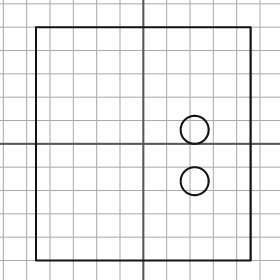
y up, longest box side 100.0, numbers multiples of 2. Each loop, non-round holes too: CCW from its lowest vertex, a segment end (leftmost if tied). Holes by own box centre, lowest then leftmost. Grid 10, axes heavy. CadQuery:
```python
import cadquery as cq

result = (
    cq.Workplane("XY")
    .moveTo(-46.0, -50.0)
    .lineTo(46.0, -50.0)
    .lineTo(46.0, 50.0)
    .lineTo(-46.0, 50.0)
    .close()
    .moveTo(22.0, -16.0)
    .circle(6.0)
    .moveTo(22.0, 6.0)
    .circle(6.0)
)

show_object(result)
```